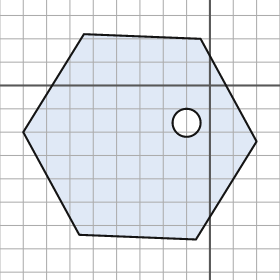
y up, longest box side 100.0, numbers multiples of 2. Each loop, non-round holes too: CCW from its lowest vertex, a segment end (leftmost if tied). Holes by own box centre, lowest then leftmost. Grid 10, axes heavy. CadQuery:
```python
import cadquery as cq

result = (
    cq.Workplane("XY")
    .moveTo(-6.0, -66.0)
    .lineTo(20.0, -24.0)
    .lineTo(-4.0, 20.0)
    .lineTo(-54.0, 22.0)
    .lineTo(-80.0, -20.0)
    .lineTo(-56.0, -64.0)
    .close()
    .moveTo(-10.0, -16.0)
    .circle(6.0)
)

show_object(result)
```